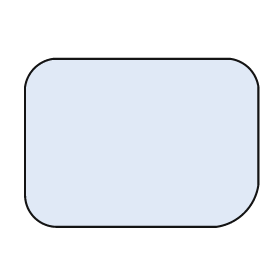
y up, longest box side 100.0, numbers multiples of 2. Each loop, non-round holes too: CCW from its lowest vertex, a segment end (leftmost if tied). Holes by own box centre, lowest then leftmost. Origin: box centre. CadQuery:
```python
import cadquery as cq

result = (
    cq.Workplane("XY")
    .moveTo(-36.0, -36.0)
    .lineTo(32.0, -36.0)
    .threePointArc((44.0, -30.0), (50.0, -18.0))
    .lineTo(50.0, 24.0)
    .threePointArc((46.0, 32.0), (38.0, 36.0))
    .lineTo(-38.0, 36.0)
    .threePointArc((-46.0, 32.0), (-50.0, 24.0))
    .lineTo(-50.0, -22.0)
    .threePointArc((-46.0, -32.0), (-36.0, -36.0))
    .close()
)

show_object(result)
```